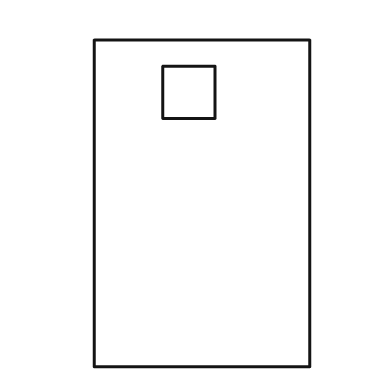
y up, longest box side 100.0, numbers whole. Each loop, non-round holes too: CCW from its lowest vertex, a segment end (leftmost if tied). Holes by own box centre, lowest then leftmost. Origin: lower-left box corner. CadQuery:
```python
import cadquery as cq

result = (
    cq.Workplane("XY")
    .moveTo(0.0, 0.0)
    .lineTo(66.0, 0.0)
    .lineTo(66.0, 100.0)
    .lineTo(0.0, 100.0)
    .close()
    .moveTo(21.0, 76.0)
    .lineTo(37.0, 76.0)
    .lineTo(37.0, 92.0)
    .lineTo(21.0, 92.0)
    .close()
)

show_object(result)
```